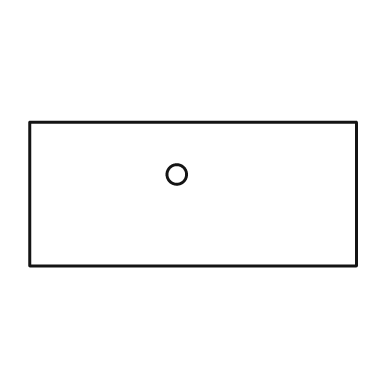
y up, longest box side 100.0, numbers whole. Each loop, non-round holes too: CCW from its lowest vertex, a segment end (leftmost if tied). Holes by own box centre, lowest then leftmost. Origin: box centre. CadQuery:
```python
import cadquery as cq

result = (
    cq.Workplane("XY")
    .moveTo(-50.0, -22.0)
    .lineTo(50.0, -22.0)
    .lineTo(50.0, 22.0)
    .lineTo(-50.0, 22.0)
    .close()
    .moveTo(-5.0, 6.0)
    .circle(3.0)
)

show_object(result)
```